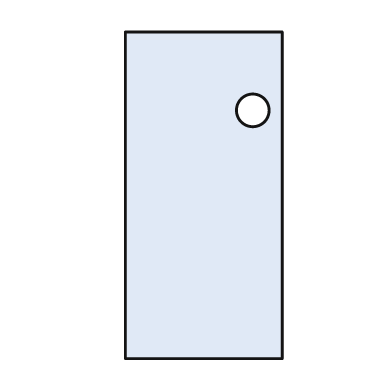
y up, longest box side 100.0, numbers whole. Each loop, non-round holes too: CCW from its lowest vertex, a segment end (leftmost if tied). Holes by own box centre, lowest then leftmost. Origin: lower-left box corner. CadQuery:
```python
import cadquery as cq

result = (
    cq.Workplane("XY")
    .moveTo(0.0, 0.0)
    .lineTo(48.0, 0.0)
    .lineTo(48.0, 100.0)
    .lineTo(0.0, 100.0)
    .close()
    .moveTo(39.0, 76.0)
    .circle(5.0)
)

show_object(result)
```